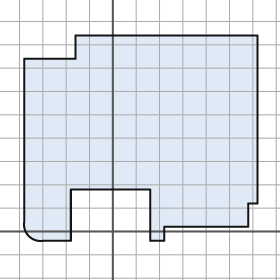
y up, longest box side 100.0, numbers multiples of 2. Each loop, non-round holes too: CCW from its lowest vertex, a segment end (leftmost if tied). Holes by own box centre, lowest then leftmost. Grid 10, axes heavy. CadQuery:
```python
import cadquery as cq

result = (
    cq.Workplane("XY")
    .moveTo(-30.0, -4.0)
    .lineTo(-18.0, -4.0)
    .lineTo(-18.0, 18.0)
    .lineTo(16.0, 18.0)
    .lineTo(16.0, -4.0)
    .lineTo(22.0, -4.0)
    .lineTo(22.0, 2.0)
    .lineTo(58.0, 2.0)
    .lineTo(58.0, 12.0)
    .lineTo(62.0, 12.0)
    .lineTo(62.0, 84.0)
    .lineTo(-16.0, 84.0)
    .lineTo(-16.0, 74.0)
    .lineTo(-38.0, 74.0)
    .lineTo(-38.0, 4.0)
    .threePointArc((-36.0, -2.0), (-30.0, -4.0))
    .close()
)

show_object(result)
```